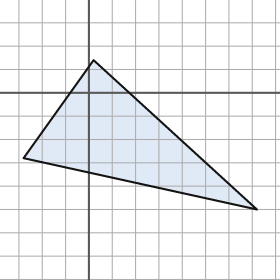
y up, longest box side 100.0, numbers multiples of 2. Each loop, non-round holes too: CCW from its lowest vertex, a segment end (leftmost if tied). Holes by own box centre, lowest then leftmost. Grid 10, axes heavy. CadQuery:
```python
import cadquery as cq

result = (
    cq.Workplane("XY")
    .moveTo(72.0, -50.0)
    .lineTo(2.0, 14.0)
    .lineTo(-28.0, -28.0)
    .close()
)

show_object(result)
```